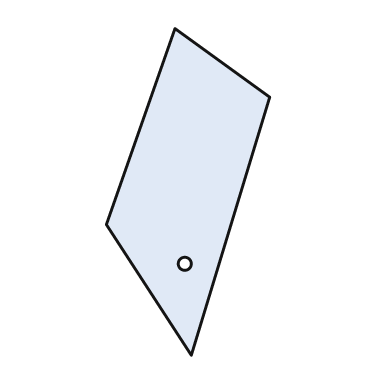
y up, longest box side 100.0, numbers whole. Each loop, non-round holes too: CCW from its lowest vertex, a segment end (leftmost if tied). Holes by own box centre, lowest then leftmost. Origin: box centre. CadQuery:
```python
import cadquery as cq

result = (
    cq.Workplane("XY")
    .moveTo(1.0, -50.0)
    .lineTo(25.0, 29.0)
    .lineTo(-4.0, 50.0)
    .lineTo(-25.0, -10.0)
    .close()
    .moveTo(-1.0, -22.0)
    .circle(2.0)
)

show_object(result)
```